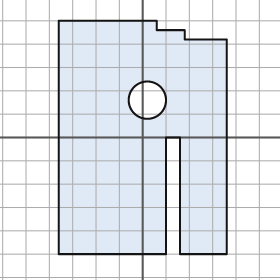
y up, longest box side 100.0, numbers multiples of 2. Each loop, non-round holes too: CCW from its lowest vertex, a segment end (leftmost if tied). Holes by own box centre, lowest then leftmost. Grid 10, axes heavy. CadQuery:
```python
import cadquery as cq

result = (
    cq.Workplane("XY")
    .moveTo(-36.0, -50.0)
    .lineTo(10.0, -50.0)
    .lineTo(10.0, 0.0)
    .lineTo(16.0, 0.0)
    .lineTo(16.0, -50.0)
    .lineTo(36.0, -50.0)
    .lineTo(36.0, 42.0)
    .lineTo(18.0, 42.0)
    .lineTo(18.0, 46.0)
    .lineTo(6.0, 46.0)
    .lineTo(6.0, 50.0)
    .lineTo(-36.0, 50.0)
    .close()
    .moveTo(2.0, 16.0)
    .circle(8.0)
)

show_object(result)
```